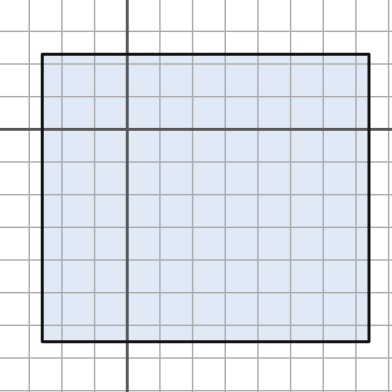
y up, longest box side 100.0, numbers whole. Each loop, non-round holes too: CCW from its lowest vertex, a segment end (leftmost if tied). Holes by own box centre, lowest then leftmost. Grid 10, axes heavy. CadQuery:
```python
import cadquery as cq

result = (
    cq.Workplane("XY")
    .moveTo(-26.0, -65.0)
    .lineTo(74.0, -65.0)
    .lineTo(74.0, 23.0)
    .lineTo(-26.0, 23.0)
    .close()
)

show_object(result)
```